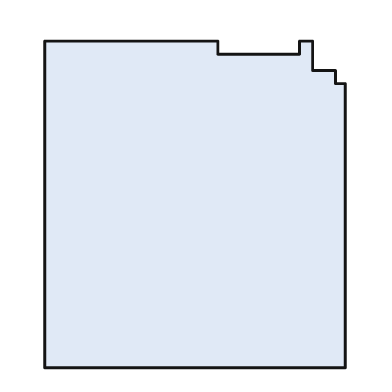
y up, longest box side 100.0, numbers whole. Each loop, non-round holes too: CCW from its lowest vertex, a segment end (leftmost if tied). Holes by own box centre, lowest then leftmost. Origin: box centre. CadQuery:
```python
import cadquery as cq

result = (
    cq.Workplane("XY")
    .moveTo(-46.0, -50.0)
    .lineTo(46.0, -50.0)
    .lineTo(46.0, 37.0)
    .lineTo(43.0, 37.0)
    .lineTo(43.0, 41.0)
    .lineTo(36.0, 41.0)
    .lineTo(36.0, 50.0)
    .lineTo(32.0, 50.0)
    .lineTo(32.0, 46.0)
    .lineTo(7.0, 46.0)
    .lineTo(7.0, 50.0)
    .lineTo(-46.0, 50.0)
    .close()
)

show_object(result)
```